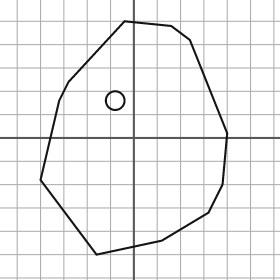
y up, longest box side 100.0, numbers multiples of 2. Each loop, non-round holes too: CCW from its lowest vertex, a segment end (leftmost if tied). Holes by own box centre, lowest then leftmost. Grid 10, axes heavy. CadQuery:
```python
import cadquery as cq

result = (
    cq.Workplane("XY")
    .moveTo(-16.0, -50.0)
    .lineTo(12.0, -44.0)
    .lineTo(32.0, -32.0)
    .lineTo(38.0, -20.0)
    .lineTo(40.0, 2.0)
    .lineTo(24.0, 42.0)
    .lineTo(16.0, 48.0)
    .lineTo(-4.0, 50.0)
    .lineTo(-28.0, 24.0)
    .lineTo(-32.0, 16.0)
    .lineTo(-40.0, -18.0)
    .close()
    .moveTo(-8.0, 16.0)
    .circle(4.0)
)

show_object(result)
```